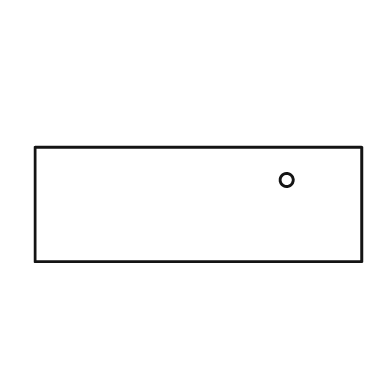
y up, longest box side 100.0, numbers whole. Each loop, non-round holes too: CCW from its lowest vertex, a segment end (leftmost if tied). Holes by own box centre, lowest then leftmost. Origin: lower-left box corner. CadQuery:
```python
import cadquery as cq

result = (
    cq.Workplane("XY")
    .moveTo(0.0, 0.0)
    .lineTo(100.0, 0.0)
    .lineTo(100.0, 35.0)
    .lineTo(0.0, 35.0)
    .close()
    .moveTo(77.0, 25.0)
    .circle(2.0)
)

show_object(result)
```